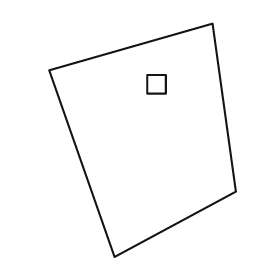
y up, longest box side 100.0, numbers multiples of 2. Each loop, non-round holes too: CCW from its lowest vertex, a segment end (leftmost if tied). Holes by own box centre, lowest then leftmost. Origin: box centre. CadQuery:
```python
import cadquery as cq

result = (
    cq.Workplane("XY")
    .moveTo(-12.0, -50.0)
    .lineTo(40.0, -22.0)
    .lineTo(30.0, 50.0)
    .lineTo(-40.0, 30.0)
    .close()
    .moveTo(2.0, 20.0)
    .lineTo(10.0, 20.0)
    .lineTo(10.0, 28.0)
    .lineTo(2.0, 28.0)
    .close()
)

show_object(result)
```